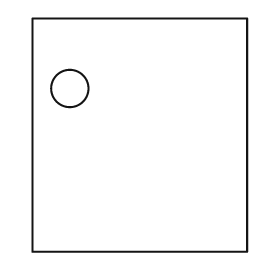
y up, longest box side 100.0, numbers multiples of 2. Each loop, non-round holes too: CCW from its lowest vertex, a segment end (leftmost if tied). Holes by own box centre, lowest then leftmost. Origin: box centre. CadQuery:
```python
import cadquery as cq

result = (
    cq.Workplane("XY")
    .moveTo(-46.0, -50.0)
    .lineTo(46.0, -50.0)
    .lineTo(46.0, 50.0)
    .lineTo(-46.0, 50.0)
    .close()
    .moveTo(-30.0, 20.0)
    .circle(8.0)
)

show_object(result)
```